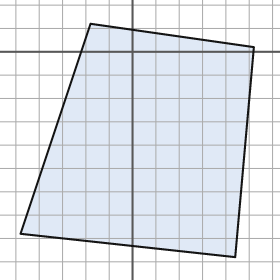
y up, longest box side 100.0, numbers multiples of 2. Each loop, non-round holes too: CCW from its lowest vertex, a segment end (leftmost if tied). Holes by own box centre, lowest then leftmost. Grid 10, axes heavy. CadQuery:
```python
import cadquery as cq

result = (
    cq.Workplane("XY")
    .moveTo(44.0, -88.0)
    .lineTo(52.0, 2.0)
    .lineTo(-18.0, 12.0)
    .lineTo(-48.0, -78.0)
    .close()
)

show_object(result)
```